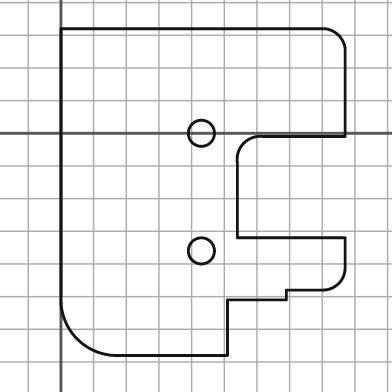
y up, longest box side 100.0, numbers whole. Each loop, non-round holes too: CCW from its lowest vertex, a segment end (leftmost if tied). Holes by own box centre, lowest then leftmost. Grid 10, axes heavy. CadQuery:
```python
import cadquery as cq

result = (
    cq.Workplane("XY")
    .moveTo(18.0, -68.0)
    .lineTo(51.0, -68.0)
    .lineTo(51.0, -51.0)
    .lineTo(69.0, -51.0)
    .lineTo(69.0, -48.0)
    .lineTo(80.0, -48.0)
    .threePointArc((85.0, -46.0), (87.0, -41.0))
    .lineTo(87.0, -32.0)
    .lineTo(54.0, -32.0)
    .lineTo(54.0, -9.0)
    .threePointArc((56.0, -3.0), (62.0, -1.0))
    .lineTo(87.0, -1.0)
    .lineTo(87.0, 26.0)
    .threePointArc((85.0, 30.0), (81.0, 32.0))
    .lineTo(0.0, 32.0)
    .lineTo(0.0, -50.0)
    .threePointArc((5.0, -63.0), (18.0, -68.0))
    .close()
    .moveTo(43.0, -36.0)
    .circle(4.0)
    .moveTo(43.0, 0.0)
    .circle(4.0)
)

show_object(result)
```